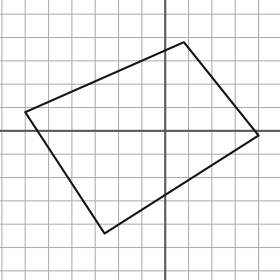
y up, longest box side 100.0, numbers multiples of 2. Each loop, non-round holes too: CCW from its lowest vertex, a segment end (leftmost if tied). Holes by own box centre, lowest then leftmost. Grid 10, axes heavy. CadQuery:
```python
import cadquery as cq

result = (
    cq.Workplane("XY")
    .moveTo(-26.0, -44.0)
    .lineTo(40.0, -2.0)
    .lineTo(8.0, 38.0)
    .lineTo(-60.0, 8.0)
    .close()
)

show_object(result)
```